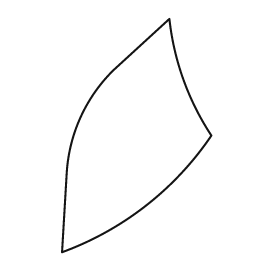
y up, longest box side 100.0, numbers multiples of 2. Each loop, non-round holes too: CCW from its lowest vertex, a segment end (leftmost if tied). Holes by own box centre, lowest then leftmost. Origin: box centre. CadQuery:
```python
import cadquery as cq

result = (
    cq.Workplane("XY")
    .moveTo(-32.0, -50.0)
    .threePointArc((4.0, -30.0), (32.0, 0.0))
    .threePointArc((20.0, 24.0), (14.0, 50.0))
    .lineTo(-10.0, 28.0)
    .threePointArc((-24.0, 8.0), (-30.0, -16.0))
    .close()
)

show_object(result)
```